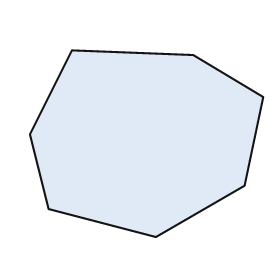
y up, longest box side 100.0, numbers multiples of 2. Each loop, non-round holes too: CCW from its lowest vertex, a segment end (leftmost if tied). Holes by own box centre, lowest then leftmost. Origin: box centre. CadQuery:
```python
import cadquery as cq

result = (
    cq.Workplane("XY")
    .moveTo(4.0, -40.0)
    .lineTo(42.0, -18.0)
    .lineTo(50.0, 20.0)
    .lineTo(20.0, 38.0)
    .lineTo(-32.0, 40.0)
    .lineTo(-50.0, 4.0)
    .lineTo(-42.0, -28.0)
    .close()
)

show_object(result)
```